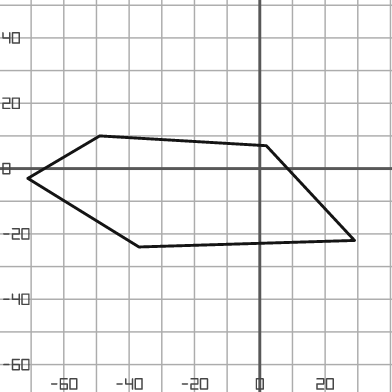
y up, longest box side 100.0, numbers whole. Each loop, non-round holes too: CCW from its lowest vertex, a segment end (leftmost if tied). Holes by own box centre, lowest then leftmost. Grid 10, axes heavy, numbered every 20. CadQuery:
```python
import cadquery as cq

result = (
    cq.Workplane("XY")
    .moveTo(-37.0, -24.0)
    .lineTo(29.0, -22.0)
    .lineTo(2.0, 7.0)
    .lineTo(-49.0, 10.0)
    .lineTo(-71.0, -3.0)
    .close()
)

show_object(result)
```